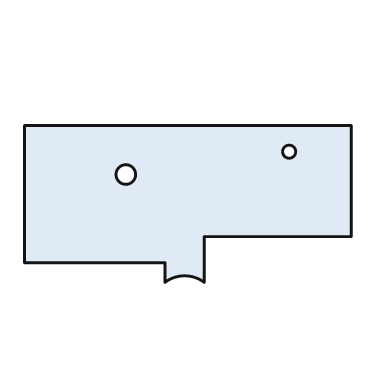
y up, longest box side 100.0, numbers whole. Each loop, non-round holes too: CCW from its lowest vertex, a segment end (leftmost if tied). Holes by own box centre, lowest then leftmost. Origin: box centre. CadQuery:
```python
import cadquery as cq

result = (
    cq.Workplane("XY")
    .moveTo(-7.0, -24.0)
    .threePointArc((-1.0, -22.0), (5.0, -24.0))
    .lineTo(5.0, -10.0)
    .lineTo(50.0, -10.0)
    .lineTo(50.0, 24.0)
    .lineTo(-50.0, 24.0)
    .lineTo(-50.0, -18.0)
    .lineTo(-7.0, -18.0)
    .close()
    .moveTo(-19.0, 9.0)
    .circle(3.0)
    .moveTo(31.0, 16.0)
    .circle(2.0)
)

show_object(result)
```